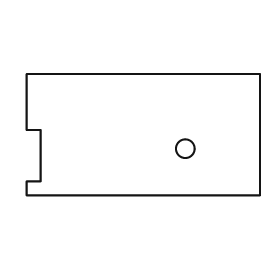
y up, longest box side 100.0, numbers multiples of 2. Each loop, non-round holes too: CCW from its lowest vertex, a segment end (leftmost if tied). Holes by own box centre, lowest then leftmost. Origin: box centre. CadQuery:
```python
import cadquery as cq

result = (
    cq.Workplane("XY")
    .moveTo(-50.0, -26.0)
    .lineTo(50.0, -26.0)
    .lineTo(50.0, 26.0)
    .lineTo(-50.0, 26.0)
    .lineTo(-50.0, 2.0)
    .lineTo(-44.0, 2.0)
    .lineTo(-44.0, -20.0)
    .lineTo(-50.0, -20.0)
    .close()
    .moveTo(18.0, -6.0)
    .circle(4.0)
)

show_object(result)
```